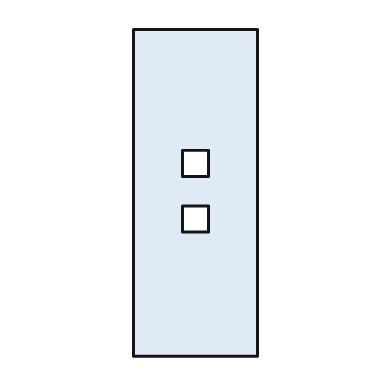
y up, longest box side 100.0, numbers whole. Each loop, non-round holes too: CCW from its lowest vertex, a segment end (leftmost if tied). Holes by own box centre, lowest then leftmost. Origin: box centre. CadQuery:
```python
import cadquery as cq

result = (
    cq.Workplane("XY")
    .moveTo(-19.0, -50.0)
    .lineTo(19.0, -50.0)
    .lineTo(19.0, 50.0)
    .lineTo(-19.0, 50.0)
    .close()
    .moveTo(-4.0, -12.0)
    .lineTo(4.0, -12.0)
    .lineTo(4.0, -4.0)
    .lineTo(-4.0, -4.0)
    .close()
    .moveTo(-4.0, 5.0)
    .lineTo(4.0, 5.0)
    .lineTo(4.0, 13.0)
    .lineTo(-4.0, 13.0)
    .close()
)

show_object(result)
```